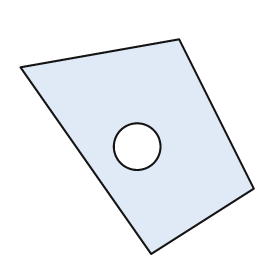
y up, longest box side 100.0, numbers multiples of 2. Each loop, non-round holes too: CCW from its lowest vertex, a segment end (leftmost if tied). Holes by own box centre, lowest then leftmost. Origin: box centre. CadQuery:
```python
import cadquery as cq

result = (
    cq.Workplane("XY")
    .moveTo(6.0, -46.0)
    .lineTo(50.0, -18.0)
    .lineTo(18.0, 46.0)
    .lineTo(-50.0, 34.0)
    .close()
    .moveTo(0.0, 0.0)
    .circle(10.0)
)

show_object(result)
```